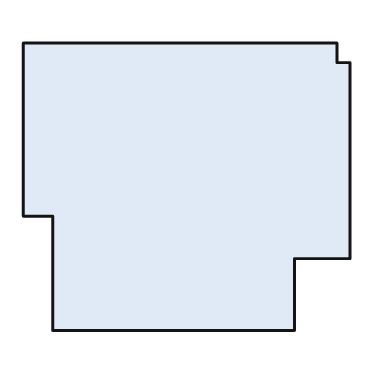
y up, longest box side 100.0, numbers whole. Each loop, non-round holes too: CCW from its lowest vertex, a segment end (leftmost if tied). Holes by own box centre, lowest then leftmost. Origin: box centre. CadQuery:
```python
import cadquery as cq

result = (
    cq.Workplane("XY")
    .moveTo(-41.0, -44.0)
    .lineTo(33.0, -44.0)
    .lineTo(33.0, -22.0)
    .lineTo(50.0, -22.0)
    .lineTo(50.0, 38.0)
    .lineTo(46.0, 38.0)
    .lineTo(46.0, 44.0)
    .lineTo(-50.0, 44.0)
    .lineTo(-50.0, -9.0)
    .lineTo(-41.0, -9.0)
    .close()
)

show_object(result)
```